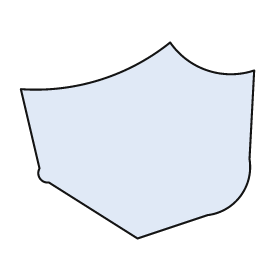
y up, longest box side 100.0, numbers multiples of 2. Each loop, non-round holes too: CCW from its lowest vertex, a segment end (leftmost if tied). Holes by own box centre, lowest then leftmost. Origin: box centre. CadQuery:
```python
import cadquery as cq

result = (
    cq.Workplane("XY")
    .moveTo(0.0, -42.0)
    .lineTo(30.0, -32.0)
    .threePointArc((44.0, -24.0), (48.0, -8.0))
    .lineTo(50.0, 30.0)
    .threePointArc((30.0, 30.0), (14.0, 42.0))
    .threePointArc((-16.0, 26.0), (-50.0, 22.0))
    .lineTo(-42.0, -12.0)
    .threePointArc((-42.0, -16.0), (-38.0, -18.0))
    .close()
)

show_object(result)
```